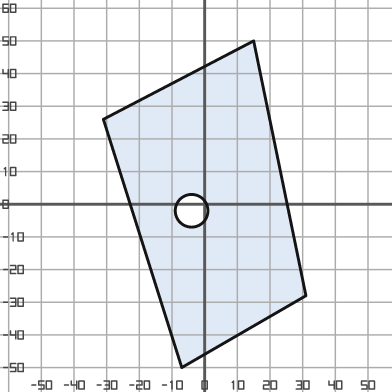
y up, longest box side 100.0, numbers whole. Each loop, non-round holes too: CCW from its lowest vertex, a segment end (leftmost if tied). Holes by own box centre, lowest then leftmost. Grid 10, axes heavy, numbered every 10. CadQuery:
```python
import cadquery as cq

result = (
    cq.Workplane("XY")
    .moveTo(-7.0, -50.0)
    .lineTo(31.0, -28.0)
    .lineTo(15.0, 50.0)
    .lineTo(-31.0, 26.0)
    .close()
    .moveTo(-4.0, -2.0)
    .circle(5.0)
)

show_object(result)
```